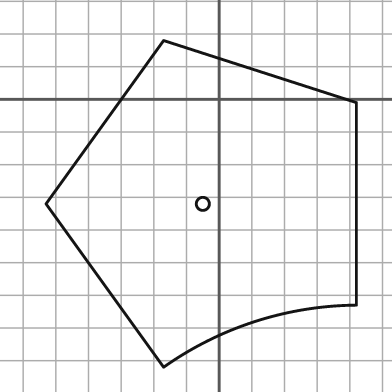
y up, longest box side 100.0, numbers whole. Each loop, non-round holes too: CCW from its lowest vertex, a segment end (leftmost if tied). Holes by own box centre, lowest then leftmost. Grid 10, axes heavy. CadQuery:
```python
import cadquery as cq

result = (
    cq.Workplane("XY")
    .moveTo(-17.0, -82.0)
    .threePointArc((11.0, -68.0), (42.0, -63.0))
    .lineTo(42.0, -1.0)
    .lineTo(-17.0, 18.0)
    .lineTo(-53.0, -32.0)
    .close()
    .moveTo(-5.0, -32.0)
    .circle(2.0)
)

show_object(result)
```